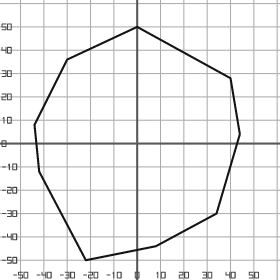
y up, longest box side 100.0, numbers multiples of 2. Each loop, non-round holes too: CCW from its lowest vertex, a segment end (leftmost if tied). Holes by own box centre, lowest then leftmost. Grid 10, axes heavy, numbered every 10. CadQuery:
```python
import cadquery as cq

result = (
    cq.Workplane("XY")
    .moveTo(-22.0, -50.0)
    .lineTo(8.0, -44.0)
    .lineTo(34.0, -30.0)
    .lineTo(44.0, 4.0)
    .lineTo(40.0, 28.0)
    .lineTo(0.0, 50.0)
    .lineTo(-30.0, 36.0)
    .lineTo(-44.0, 8.0)
    .lineTo(-42.0, -12.0)
    .close()
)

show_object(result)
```